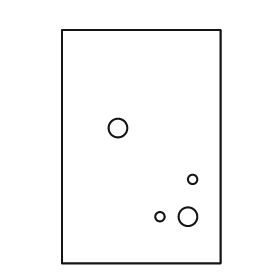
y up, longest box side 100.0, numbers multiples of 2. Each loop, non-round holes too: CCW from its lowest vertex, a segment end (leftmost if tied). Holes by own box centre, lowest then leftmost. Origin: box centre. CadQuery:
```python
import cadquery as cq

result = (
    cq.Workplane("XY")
    .moveTo(-34.0, -50.0)
    .lineTo(34.0, -50.0)
    .lineTo(34.0, 50.0)
    .lineTo(-34.0, 50.0)
    .close()
    .moveTo(8.0, -30.0)
    .circle(2.0)
    .moveTo(20.0, -30.0)
    .circle(4.0)
    .moveTo(22.0, -14.0)
    .circle(2.0)
    .moveTo(-10.0, 8.0)
    .circle(4.0)
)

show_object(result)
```